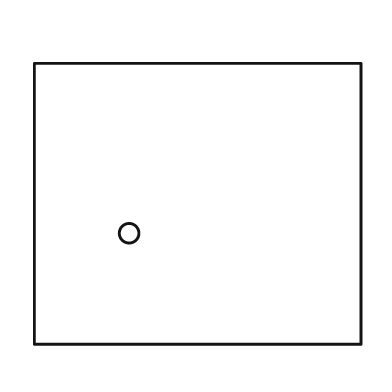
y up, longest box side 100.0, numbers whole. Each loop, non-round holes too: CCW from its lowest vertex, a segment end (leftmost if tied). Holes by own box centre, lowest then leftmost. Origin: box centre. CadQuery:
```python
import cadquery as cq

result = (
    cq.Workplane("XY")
    .moveTo(-50.0, -43.0)
    .lineTo(50.0, -43.0)
    .lineTo(50.0, 43.0)
    .lineTo(-50.0, 43.0)
    .close()
    .moveTo(-21.0, -9.0)
    .circle(3.0)
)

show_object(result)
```